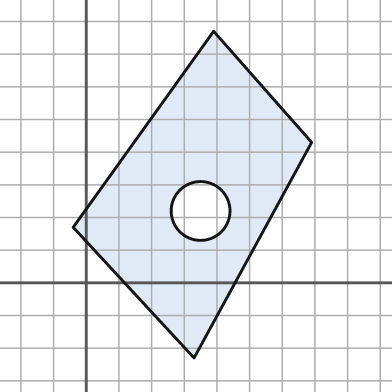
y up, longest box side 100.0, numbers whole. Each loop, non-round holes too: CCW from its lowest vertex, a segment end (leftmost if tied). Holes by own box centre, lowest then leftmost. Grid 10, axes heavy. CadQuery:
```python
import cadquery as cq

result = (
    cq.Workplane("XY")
    .moveTo(33.0, -23.0)
    .lineTo(69.0, 43.0)
    .lineTo(39.0, 77.0)
    .lineTo(-4.0, 17.0)
    .close()
    .moveTo(35.0, 22.0)
    .circle(9.0)
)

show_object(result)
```